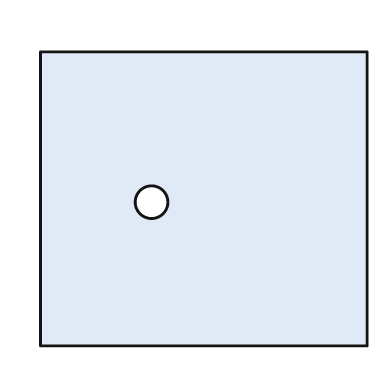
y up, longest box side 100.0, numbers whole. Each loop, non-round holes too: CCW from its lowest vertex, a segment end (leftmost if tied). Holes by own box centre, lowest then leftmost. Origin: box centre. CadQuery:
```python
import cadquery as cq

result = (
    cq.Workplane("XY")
    .moveTo(-50.0, -45.0)
    .lineTo(50.0, -45.0)
    .lineTo(50.0, 45.0)
    .lineTo(-50.0, 45.0)
    .close()
    .moveTo(-16.0, -1.0)
    .circle(5.0)
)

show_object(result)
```